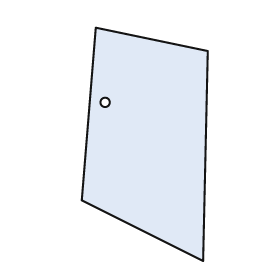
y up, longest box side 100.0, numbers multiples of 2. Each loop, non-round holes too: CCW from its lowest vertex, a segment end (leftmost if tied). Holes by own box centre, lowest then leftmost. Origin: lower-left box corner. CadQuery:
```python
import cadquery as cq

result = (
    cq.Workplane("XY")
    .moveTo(52.0, 0.0)
    .lineTo(54.0, 90.0)
    .lineTo(6.0, 100.0)
    .lineTo(0.0, 26.0)
    .close()
    .moveTo(10.0, 68.0)
    .circle(2.0)
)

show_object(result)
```